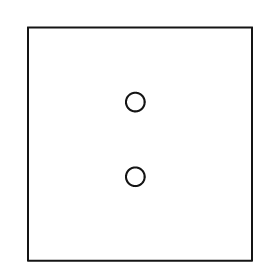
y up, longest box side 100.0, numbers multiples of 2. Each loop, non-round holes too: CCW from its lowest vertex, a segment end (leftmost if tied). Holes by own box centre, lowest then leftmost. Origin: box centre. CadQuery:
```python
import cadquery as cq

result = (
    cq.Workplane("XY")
    .moveTo(-48.0, -50.0)
    .lineTo(48.0, -50.0)
    .lineTo(48.0, 50.0)
    .lineTo(-48.0, 50.0)
    .close()
    .moveTo(-2.0, -14.0)
    .circle(4.0)
    .moveTo(-2.0, 18.0)
    .circle(4.0)
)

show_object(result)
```